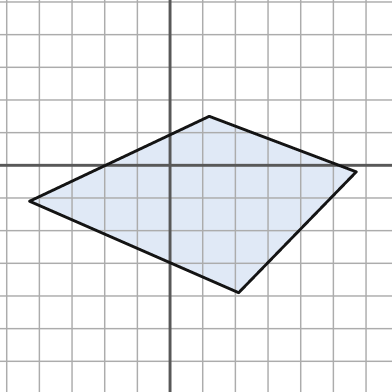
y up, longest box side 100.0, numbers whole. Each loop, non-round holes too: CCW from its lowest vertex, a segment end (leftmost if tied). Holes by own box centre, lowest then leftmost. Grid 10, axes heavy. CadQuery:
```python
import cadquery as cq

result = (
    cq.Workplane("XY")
    .moveTo(21.0, -39.0)
    .lineTo(57.0, -2.0)
    .lineTo(12.0, 15.0)
    .lineTo(-43.0, -11.0)
    .close()
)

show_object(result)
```